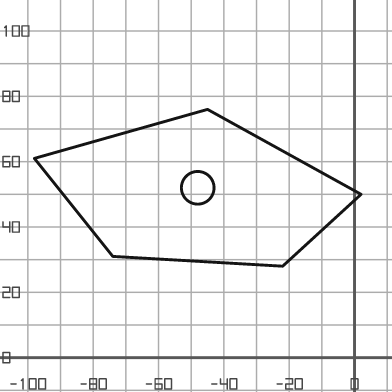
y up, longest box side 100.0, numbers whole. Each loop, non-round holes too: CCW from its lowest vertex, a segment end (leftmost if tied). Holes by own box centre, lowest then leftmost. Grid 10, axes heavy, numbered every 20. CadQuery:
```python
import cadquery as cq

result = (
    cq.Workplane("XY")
    .moveTo(-22.0, 28.0)
    .lineTo(2.0, 50.0)
    .lineTo(-45.0, 76.0)
    .lineTo(-98.0, 61.0)
    .lineTo(-74.0, 31.0)
    .close()
    .moveTo(-48.0, 52.0)
    .circle(5.0)
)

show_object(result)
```